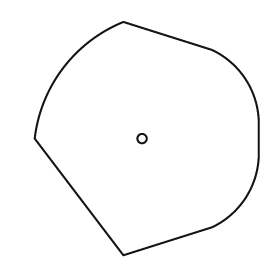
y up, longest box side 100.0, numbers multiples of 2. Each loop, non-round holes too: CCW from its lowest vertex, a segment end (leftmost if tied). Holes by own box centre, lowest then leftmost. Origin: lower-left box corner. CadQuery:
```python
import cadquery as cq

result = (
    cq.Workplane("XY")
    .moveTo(38.0, 0.0)
    .lineTo(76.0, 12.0)
    .threePointArc((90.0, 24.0), (96.0, 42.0))
    .lineTo(96.0, 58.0)
    .threePointArc((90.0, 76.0), (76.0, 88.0))
    .lineTo(38.0, 100.0)
    .threePointArc((12.0, 80.0), (0.0, 50.0))
    .close()
    .moveTo(46.0, 50.0)
    .circle(2.0)
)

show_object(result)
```